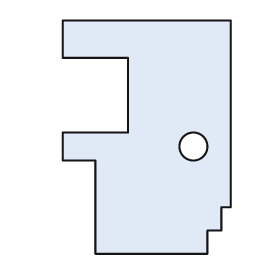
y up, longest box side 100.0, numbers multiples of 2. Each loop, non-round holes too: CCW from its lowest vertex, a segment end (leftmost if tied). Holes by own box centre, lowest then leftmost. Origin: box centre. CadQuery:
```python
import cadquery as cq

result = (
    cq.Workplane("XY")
    .moveTo(-22.0, -50.0)
    .lineTo(26.0, -50.0)
    .lineTo(26.0, -40.0)
    .lineTo(32.0, -40.0)
    .lineTo(32.0, -30.0)
    .lineTo(36.0, -30.0)
    .lineTo(36.0, 50.0)
    .lineTo(-36.0, 50.0)
    .lineTo(-36.0, 34.0)
    .lineTo(-8.0, 34.0)
    .lineTo(-8.0, 2.0)
    .lineTo(-36.0, 2.0)
    .lineTo(-36.0, -10.0)
    .lineTo(-22.0, -10.0)
    .close()
    .moveTo(20.0, -4.0)
    .circle(6.0)
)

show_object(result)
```